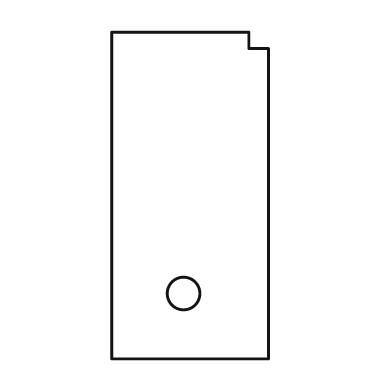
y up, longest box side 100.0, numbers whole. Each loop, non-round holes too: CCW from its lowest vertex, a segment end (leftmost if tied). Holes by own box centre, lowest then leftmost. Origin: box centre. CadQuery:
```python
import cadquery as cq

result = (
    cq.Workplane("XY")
    .moveTo(-24.0, -50.0)
    .lineTo(24.0, -50.0)
    .lineTo(24.0, 45.0)
    .lineTo(18.0, 45.0)
    .lineTo(18.0, 50.0)
    .lineTo(-24.0, 50.0)
    .close()
    .moveTo(-2.0, -30.0)
    .circle(5.0)
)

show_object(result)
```